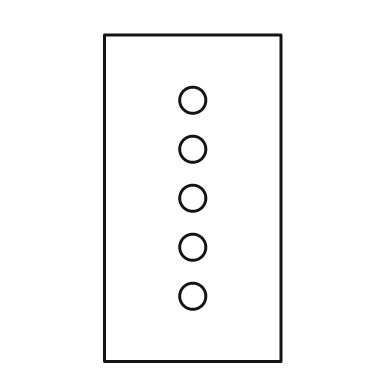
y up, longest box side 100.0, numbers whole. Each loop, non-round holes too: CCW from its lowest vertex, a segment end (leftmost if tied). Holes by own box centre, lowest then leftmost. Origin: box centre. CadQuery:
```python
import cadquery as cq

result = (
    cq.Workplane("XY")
    .moveTo(-27.0, -50.0)
    .lineTo(27.0, -50.0)
    .lineTo(27.0, 50.0)
    .lineTo(-27.0, 50.0)
    .close()
    .moveTo(0.0, -30.0)
    .circle(4.0)
    .moveTo(0.0, -15.0)
    .circle(4.0)
    .moveTo(0.0, 0.0)
    .circle(4.0)
    .moveTo(0.0, 15.0)
    .circle(4.0)
    .moveTo(0.0, 30.0)
    .circle(4.0)
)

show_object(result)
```